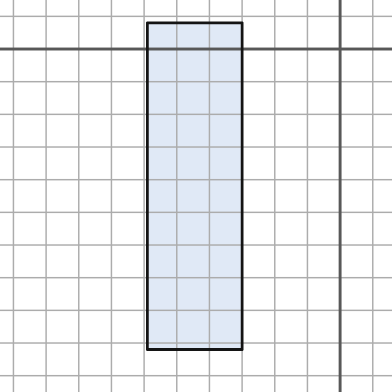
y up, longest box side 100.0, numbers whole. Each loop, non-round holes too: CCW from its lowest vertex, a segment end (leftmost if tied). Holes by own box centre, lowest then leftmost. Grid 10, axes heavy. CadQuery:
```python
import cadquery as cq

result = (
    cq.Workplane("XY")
    .moveTo(-59.0, -92.0)
    .lineTo(-30.0, -92.0)
    .lineTo(-30.0, 8.0)
    .lineTo(-59.0, 8.0)
    .close()
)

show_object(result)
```